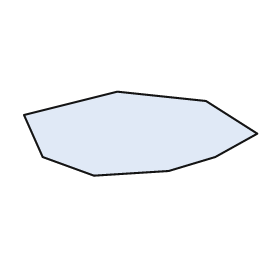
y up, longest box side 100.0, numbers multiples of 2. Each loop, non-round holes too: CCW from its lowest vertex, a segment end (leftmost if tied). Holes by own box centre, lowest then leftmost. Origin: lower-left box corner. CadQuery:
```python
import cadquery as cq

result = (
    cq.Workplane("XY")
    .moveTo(30.0, 0.0)
    .lineTo(62.0, 2.0)
    .lineTo(82.0, 8.0)
    .lineTo(100.0, 18.0)
    .lineTo(78.0, 32.0)
    .lineTo(40.0, 36.0)
    .lineTo(0.0, 26.0)
    .lineTo(8.0, 8.0)
    .close()
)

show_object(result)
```